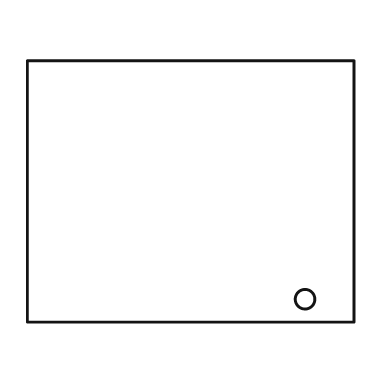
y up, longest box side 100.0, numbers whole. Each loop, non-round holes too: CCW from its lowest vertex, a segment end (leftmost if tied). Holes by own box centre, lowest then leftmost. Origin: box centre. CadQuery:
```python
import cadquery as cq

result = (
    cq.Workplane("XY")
    .moveTo(-50.0, -40.0)
    .lineTo(50.0, -40.0)
    .lineTo(50.0, 40.0)
    .lineTo(-50.0, 40.0)
    .close()
    .moveTo(35.0, -33.0)
    .circle(3.0)
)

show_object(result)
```